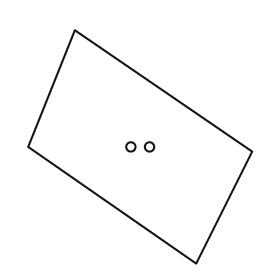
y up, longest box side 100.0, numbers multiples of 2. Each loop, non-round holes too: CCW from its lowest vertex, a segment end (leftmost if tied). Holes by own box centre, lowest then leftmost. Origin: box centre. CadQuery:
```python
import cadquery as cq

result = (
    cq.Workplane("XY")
    .moveTo(24.0, -50.0)
    .lineTo(48.0, -2.0)
    .lineTo(-28.0, 50.0)
    .lineTo(-48.0, 0.0)
    .close()
    .moveTo(-4.0, 0.0)
    .circle(2.0)
    .moveTo(4.0, 0.0)
    .circle(2.0)
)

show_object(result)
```